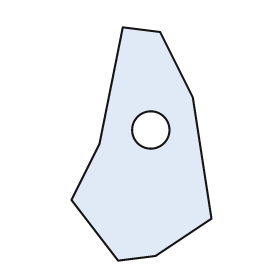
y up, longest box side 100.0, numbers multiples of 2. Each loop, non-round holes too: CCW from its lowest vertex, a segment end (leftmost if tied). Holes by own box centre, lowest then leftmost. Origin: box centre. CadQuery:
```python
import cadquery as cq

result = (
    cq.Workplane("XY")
    .moveTo(-10.0, -50.0)
    .lineTo(6.0, -48.0)
    .lineTo(30.0, -32.0)
    .lineTo(22.0, 20.0)
    .lineTo(8.0, 48.0)
    .lineTo(-8.0, 50.0)
    .lineTo(-18.0, 0.0)
    .lineTo(-30.0, -24.0)
    .close()
    .moveTo(4.0, 6.0)
    .circle(8.0)
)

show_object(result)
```